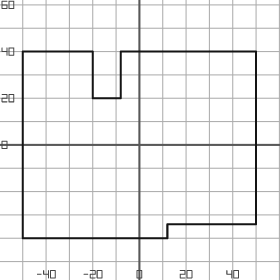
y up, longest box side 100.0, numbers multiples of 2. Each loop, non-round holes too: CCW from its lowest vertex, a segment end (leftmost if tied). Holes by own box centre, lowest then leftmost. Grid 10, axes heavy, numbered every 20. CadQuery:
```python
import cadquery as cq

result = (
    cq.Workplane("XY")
    .moveTo(-50.0, -40.0)
    .lineTo(12.0, -40.0)
    .lineTo(12.0, -34.0)
    .lineTo(50.0, -34.0)
    .lineTo(50.0, 40.0)
    .lineTo(-8.0, 40.0)
    .lineTo(-8.0, 20.0)
    .lineTo(-20.0, 20.0)
    .lineTo(-20.0, 40.0)
    .lineTo(-50.0, 40.0)
    .close()
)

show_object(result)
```